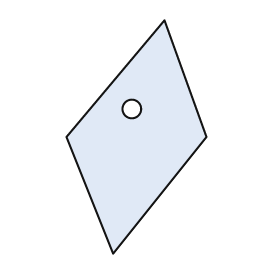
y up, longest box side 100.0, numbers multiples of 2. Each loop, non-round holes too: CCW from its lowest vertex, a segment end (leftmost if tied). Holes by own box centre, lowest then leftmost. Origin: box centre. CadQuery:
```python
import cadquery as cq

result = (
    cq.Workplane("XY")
    .moveTo(-10.0, -50.0)
    .lineTo(30.0, 0.0)
    .lineTo(12.0, 50.0)
    .lineTo(-30.0, 0.0)
    .close()
    .moveTo(-2.0, 12.0)
    .circle(4.0)
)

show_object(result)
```